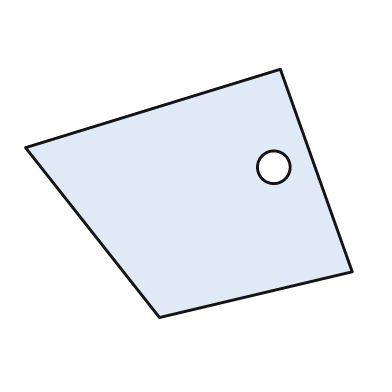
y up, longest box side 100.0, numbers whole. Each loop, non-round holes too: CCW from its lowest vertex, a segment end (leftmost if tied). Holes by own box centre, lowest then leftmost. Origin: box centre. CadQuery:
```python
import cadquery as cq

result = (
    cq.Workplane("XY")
    .moveTo(-9.0, -38.0)
    .lineTo(50.0, -24.0)
    .lineTo(28.0, 38.0)
    .lineTo(-50.0, 14.0)
    .close()
    .moveTo(26.0, 8.0)
    .circle(5.0)
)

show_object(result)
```